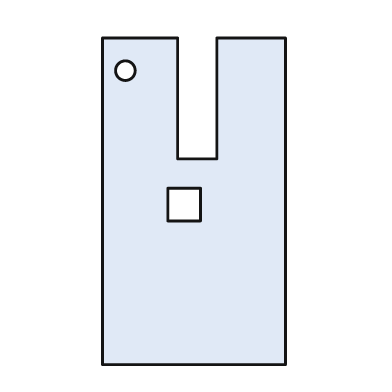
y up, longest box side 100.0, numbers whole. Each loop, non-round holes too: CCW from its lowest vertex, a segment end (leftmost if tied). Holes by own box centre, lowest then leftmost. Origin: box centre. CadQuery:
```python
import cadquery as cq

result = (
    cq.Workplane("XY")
    .moveTo(-28.0, -50.0)
    .lineTo(28.0, -50.0)
    .lineTo(28.0, 50.0)
    .lineTo(7.0, 50.0)
    .lineTo(7.0, 13.0)
    .lineTo(-5.0, 13.0)
    .lineTo(-5.0, 50.0)
    .lineTo(-28.0, 50.0)
    .close()
    .moveTo(-8.0, -6.0)
    .lineTo(2.0, -6.0)
    .lineTo(2.0, 4.0)
    .lineTo(-8.0, 4.0)
    .close()
    .moveTo(-21.0, 40.0)
    .circle(3.0)
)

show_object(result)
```